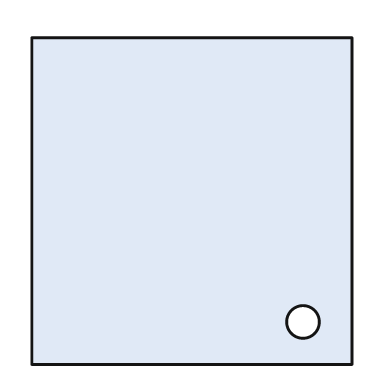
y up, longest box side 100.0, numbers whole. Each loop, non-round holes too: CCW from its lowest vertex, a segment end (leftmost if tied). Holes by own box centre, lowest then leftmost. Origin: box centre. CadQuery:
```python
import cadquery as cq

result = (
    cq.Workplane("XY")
    .moveTo(-49.0, -50.0)
    .lineTo(49.0, -50.0)
    .lineTo(49.0, 50.0)
    .lineTo(-49.0, 50.0)
    .close()
    .moveTo(34.0, -37.0)
    .circle(5.0)
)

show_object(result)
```